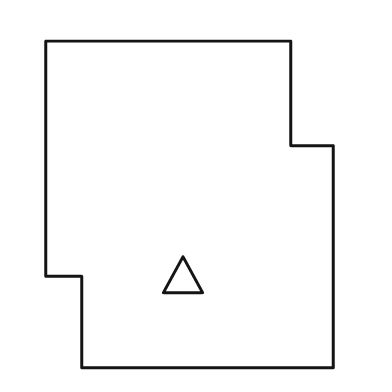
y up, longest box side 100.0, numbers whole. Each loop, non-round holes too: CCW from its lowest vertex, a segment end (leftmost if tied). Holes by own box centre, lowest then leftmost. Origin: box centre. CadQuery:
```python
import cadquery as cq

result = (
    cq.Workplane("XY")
    .moveTo(-33.0, -50.0)
    .lineTo(44.0, -50.0)
    .lineTo(44.0, 18.0)
    .lineTo(31.0, 18.0)
    .lineTo(31.0, 50.0)
    .lineTo(-44.0, 50.0)
    .lineTo(-44.0, -22.0)
    .lineTo(-33.0, -22.0)
    .close()
    .moveTo(-8.0, -27.0)
    .lineTo(4.0, -27.0)
    .lineTo(-2.0, -16.0)
    .close()
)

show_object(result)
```